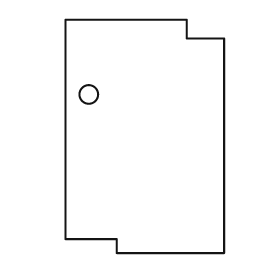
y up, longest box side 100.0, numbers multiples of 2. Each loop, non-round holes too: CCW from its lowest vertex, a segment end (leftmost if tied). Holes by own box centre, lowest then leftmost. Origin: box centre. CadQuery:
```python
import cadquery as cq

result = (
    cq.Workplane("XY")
    .moveTo(-12.0, -50.0)
    .lineTo(34.0, -50.0)
    .lineTo(34.0, 42.0)
    .lineTo(18.0, 42.0)
    .lineTo(18.0, 50.0)
    .lineTo(-34.0, 50.0)
    .lineTo(-34.0, -44.0)
    .lineTo(-12.0, -44.0)
    .close()
    .moveTo(-24.0, 18.0)
    .circle(4.0)
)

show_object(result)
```